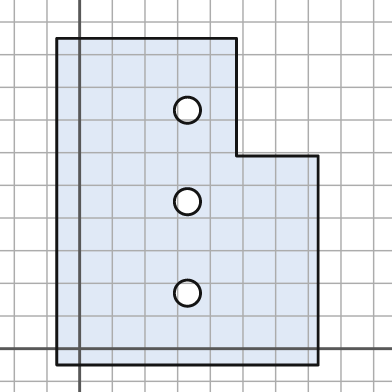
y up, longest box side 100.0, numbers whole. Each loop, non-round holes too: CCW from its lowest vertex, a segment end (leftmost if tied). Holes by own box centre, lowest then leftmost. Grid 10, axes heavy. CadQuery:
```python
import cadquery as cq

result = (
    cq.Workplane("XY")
    .moveTo(-7.0, -5.0)
    .lineTo(73.0, -5.0)
    .lineTo(73.0, 59.0)
    .lineTo(48.0, 59.0)
    .lineTo(48.0, 95.0)
    .lineTo(-7.0, 95.0)
    .close()
    .moveTo(33.0, 17.0)
    .circle(4.0)
    .moveTo(33.0, 45.0)
    .circle(4.0)
    .moveTo(33.0, 73.0)
    .circle(4.0)
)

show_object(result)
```